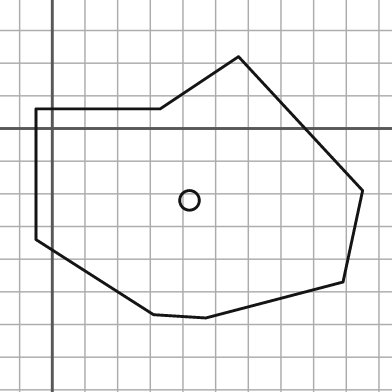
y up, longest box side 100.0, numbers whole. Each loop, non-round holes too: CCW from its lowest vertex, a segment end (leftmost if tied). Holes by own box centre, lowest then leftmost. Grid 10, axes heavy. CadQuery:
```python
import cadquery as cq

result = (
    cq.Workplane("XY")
    .moveTo(47.0, -58.0)
    .lineTo(89.0, -47.0)
    .lineTo(95.0, -19.0)
    .lineTo(57.0, 22.0)
    .lineTo(33.0, 6.0)
    .lineTo(-5.0, 6.0)
    .lineTo(-5.0, -34.0)
    .lineTo(31.0, -57.0)
    .close()
    .moveTo(42.0, -22.0)
    .circle(3.0)
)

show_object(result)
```